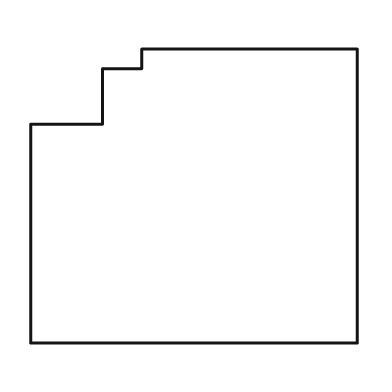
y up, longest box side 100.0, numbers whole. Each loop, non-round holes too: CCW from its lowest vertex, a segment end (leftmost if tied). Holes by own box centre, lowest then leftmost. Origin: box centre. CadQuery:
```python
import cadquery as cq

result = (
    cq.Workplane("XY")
    .moveTo(-50.0, -45.0)
    .lineTo(50.0, -45.0)
    .lineTo(50.0, 45.0)
    .lineTo(-16.0, 45.0)
    .lineTo(-16.0, 39.0)
    .lineTo(-28.0, 39.0)
    .lineTo(-28.0, 22.0)
    .lineTo(-50.0, 22.0)
    .close()
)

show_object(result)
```